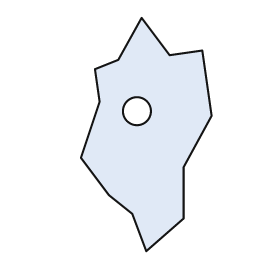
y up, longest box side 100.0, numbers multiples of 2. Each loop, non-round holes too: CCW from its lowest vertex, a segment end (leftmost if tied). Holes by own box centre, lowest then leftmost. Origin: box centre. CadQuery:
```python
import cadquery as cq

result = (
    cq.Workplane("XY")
    .moveTo(0.0, -50.0)
    .lineTo(16.0, -36.0)
    .lineTo(16.0, -14.0)
    .lineTo(28.0, 8.0)
    .lineTo(24.0, 36.0)
    .lineTo(10.0, 34.0)
    .lineTo(-2.0, 50.0)
    .lineTo(-12.0, 32.0)
    .lineTo(-22.0, 28.0)
    .lineTo(-20.0, 14.0)
    .lineTo(-28.0, -10.0)
    .lineTo(-16.0, -26.0)
    .lineTo(-6.0, -34.0)
    .close()
    .moveTo(-4.0, 10.0)
    .circle(6.0)
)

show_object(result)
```